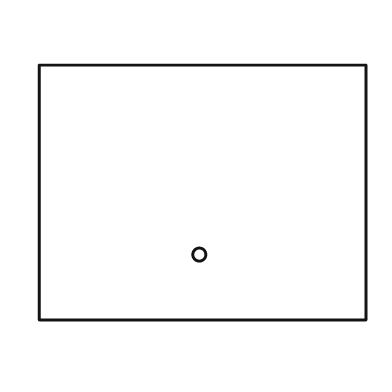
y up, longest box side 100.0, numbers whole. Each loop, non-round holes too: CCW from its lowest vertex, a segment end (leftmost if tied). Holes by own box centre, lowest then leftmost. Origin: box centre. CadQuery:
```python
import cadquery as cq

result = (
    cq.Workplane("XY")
    .moveTo(-50.0, -39.0)
    .lineTo(50.0, -39.0)
    .lineTo(50.0, 39.0)
    .lineTo(-50.0, 39.0)
    .close()
    .moveTo(-1.0, -19.0)
    .circle(2.0)
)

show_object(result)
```